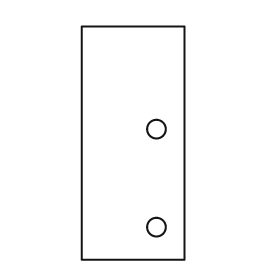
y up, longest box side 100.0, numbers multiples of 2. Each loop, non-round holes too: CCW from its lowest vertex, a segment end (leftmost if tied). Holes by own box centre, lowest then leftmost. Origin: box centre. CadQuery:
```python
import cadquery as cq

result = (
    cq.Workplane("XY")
    .moveTo(-22.0, -50.0)
    .lineTo(22.0, -50.0)
    .lineTo(22.0, 50.0)
    .lineTo(-22.0, 50.0)
    .close()
    .moveTo(10.0, -36.0)
    .circle(4.0)
    .moveTo(10.0, 6.0)
    .circle(4.0)
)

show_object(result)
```